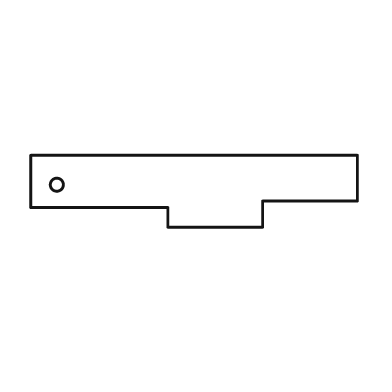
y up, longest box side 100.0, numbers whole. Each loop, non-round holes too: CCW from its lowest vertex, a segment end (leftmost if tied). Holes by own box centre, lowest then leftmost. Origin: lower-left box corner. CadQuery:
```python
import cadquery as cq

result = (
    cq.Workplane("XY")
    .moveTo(42.0, 0.0)
    .lineTo(71.0, 0.0)
    .lineTo(71.0, 8.0)
    .lineTo(100.0, 8.0)
    .lineTo(100.0, 22.0)
    .lineTo(0.0, 22.0)
    .lineTo(0.0, 6.0)
    .lineTo(42.0, 6.0)
    .close()
    .moveTo(8.0, 13.0)
    .circle(2.0)
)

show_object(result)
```